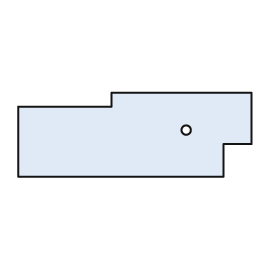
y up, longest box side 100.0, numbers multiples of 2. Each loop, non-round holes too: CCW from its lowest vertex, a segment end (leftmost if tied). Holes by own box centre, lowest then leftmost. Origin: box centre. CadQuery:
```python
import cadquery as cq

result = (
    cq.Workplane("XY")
    .moveTo(-50.0, -18.0)
    .lineTo(38.0, -18.0)
    .lineTo(38.0, -4.0)
    .lineTo(50.0, -4.0)
    .lineTo(50.0, 18.0)
    .lineTo(-10.0, 18.0)
    .lineTo(-10.0, 12.0)
    .lineTo(-50.0, 12.0)
    .close()
    .moveTo(22.0, 2.0)
    .circle(2.0)
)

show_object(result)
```